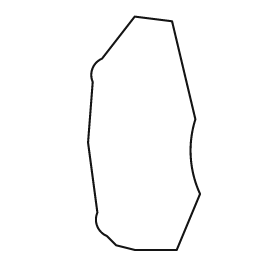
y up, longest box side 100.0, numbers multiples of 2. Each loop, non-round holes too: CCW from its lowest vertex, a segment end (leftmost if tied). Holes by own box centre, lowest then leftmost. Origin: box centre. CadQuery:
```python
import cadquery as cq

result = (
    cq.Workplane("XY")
    .moveTo(-4.0, -50.0)
    .lineTo(14.0, -50.0)
    .lineTo(24.0, -26.0)
    .threePointArc((20.0, -10.0), (22.0, 6.0))
    .lineTo(12.0, 48.0)
    .lineTo(-4.0, 50.0)
    .lineTo(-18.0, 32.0)
    .threePointArc((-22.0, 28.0), (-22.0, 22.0))
    .lineTo(-24.0, -4.0)
    .lineTo(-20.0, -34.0)
    .threePointArc((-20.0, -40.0), (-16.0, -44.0))
    .lineTo(-12.0, -48.0)
    .close()
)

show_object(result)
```